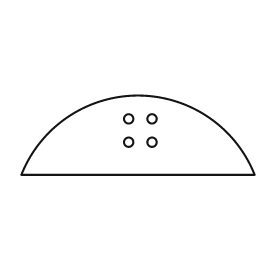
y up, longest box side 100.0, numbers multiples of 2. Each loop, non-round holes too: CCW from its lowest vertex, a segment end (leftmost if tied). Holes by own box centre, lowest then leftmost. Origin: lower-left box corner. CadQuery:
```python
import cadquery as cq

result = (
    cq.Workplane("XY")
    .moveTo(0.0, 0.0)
    .lineTo(100.0, 0.0)
    .threePointArc((50.0, 34.0), (0.0, 0.0))
    .close()
    .moveTo(46.0, 14.0)
    .circle(2.0)
    .moveTo(56.0, 14.0)
    .circle(2.0)
    .moveTo(46.0, 24.0)
    .circle(2.0)
    .moveTo(56.0, 24.0)
    .circle(2.0)
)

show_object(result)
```